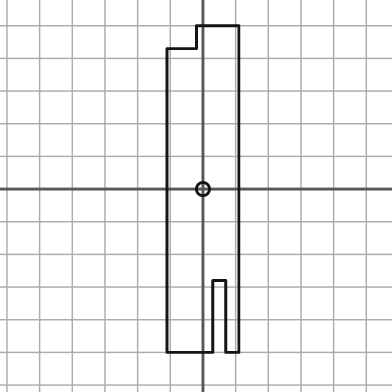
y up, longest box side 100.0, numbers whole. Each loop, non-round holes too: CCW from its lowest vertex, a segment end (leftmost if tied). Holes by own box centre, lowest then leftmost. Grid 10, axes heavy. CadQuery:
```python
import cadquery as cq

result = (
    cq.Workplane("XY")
    .moveTo(-11.0, -50.0)
    .lineTo(3.0, -50.0)
    .lineTo(3.0, -28.0)
    .lineTo(7.0, -28.0)
    .lineTo(7.0, -50.0)
    .lineTo(11.0, -50.0)
    .lineTo(11.0, 50.0)
    .lineTo(-2.0, 50.0)
    .lineTo(-2.0, 43.0)
    .lineTo(-11.0, 43.0)
    .close()
    .moveTo(0.0, 0.0)
    .circle(2.0)
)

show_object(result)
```